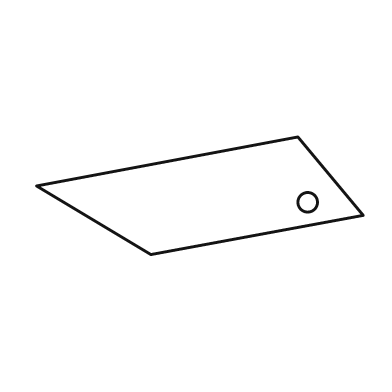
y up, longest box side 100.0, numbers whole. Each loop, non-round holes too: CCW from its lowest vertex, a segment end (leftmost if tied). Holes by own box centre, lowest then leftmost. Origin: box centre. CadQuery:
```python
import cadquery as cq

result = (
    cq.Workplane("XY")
    .moveTo(-15.0, -18.0)
    .lineTo(50.0, -6.0)
    .lineTo(30.0, 18.0)
    .lineTo(-50.0, 3.0)
    .close()
    .moveTo(33.0, -2.0)
    .circle(3.0)
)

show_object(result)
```